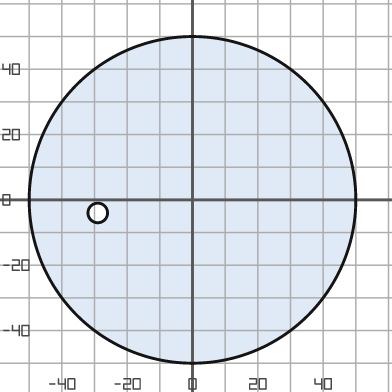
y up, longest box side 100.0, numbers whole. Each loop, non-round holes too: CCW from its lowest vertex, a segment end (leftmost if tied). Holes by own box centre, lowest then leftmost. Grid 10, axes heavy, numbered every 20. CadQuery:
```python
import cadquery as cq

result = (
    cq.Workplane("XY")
    .moveTo(0.0, 0.0)
    .circle(50.0)
    .moveTo(-29.0, -4.0)
    .circle(3.0)
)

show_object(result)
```